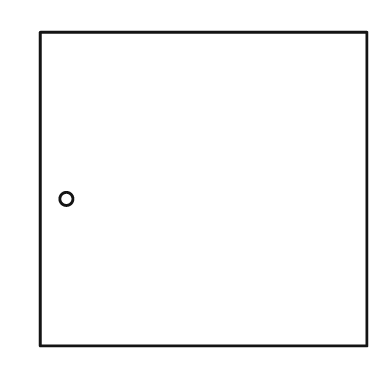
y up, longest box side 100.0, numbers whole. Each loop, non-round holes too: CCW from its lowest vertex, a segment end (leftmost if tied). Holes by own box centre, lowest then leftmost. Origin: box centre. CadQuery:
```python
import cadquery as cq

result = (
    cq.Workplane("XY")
    .moveTo(-50.0, -48.0)
    .lineTo(50.0, -48.0)
    .lineTo(50.0, 48.0)
    .lineTo(-50.0, 48.0)
    .close()
    .moveTo(-42.0, -3.0)
    .circle(2.0)
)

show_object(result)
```